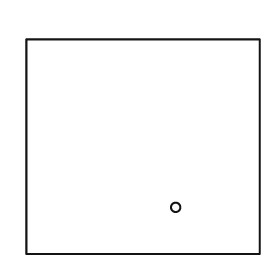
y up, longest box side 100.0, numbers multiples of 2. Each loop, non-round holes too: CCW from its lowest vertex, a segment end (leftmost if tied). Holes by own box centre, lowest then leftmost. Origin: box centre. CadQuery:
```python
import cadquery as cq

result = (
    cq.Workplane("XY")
    .moveTo(-50.0, -46.0)
    .lineTo(50.0, -46.0)
    .lineTo(50.0, 46.0)
    .lineTo(-50.0, 46.0)
    .close()
    .moveTo(14.0, -26.0)
    .circle(2.0)
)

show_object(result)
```